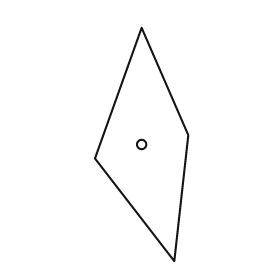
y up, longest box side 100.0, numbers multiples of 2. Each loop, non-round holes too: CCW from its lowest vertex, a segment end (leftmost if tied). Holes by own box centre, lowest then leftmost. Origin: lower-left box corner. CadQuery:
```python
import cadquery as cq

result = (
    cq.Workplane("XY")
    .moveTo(34.0, 0.0)
    .lineTo(40.0, 54.0)
    .lineTo(20.0, 100.0)
    .lineTo(0.0, 44.0)
    .close()
    .moveTo(20.0, 50.0)
    .circle(2.0)
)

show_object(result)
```